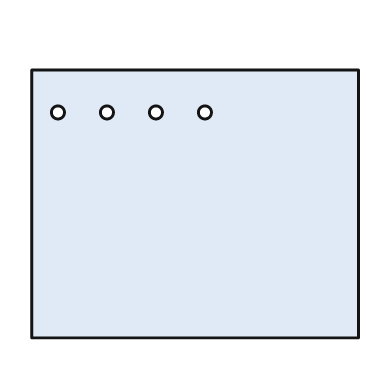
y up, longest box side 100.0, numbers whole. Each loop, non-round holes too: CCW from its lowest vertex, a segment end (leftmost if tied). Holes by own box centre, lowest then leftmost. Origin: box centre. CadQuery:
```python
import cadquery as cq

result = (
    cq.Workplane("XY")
    .moveTo(-50.0, -41.0)
    .lineTo(50.0, -41.0)
    .lineTo(50.0, 41.0)
    .lineTo(-50.0, 41.0)
    .close()
    .moveTo(-42.0, 28.0)
    .circle(2.0)
    .moveTo(-27.0, 28.0)
    .circle(2.0)
    .moveTo(-12.0, 28.0)
    .circle(2.0)
    .moveTo(3.0, 28.0)
    .circle(2.0)
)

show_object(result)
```